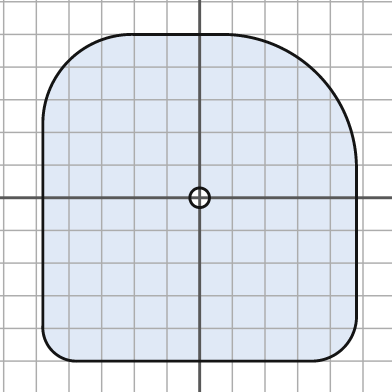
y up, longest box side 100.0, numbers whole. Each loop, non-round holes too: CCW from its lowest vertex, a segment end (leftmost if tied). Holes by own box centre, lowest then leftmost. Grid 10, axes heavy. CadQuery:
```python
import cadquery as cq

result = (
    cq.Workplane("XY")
    .moveTo(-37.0, -50.0)
    .lineTo(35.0, -50.0)
    .threePointArc((44.0, -46.0), (48.0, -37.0))
    .lineTo(48.0, 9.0)
    .threePointArc((36.0, 38.0), (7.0, 50.0))
    .lineTo(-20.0, 50.0)
    .threePointArc((-40.0, 42.0), (-48.0, 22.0))
    .lineTo(-48.0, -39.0)
    .threePointArc((-45.0, -47.0), (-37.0, -50.0))
    .close()
    .moveTo(0.0, 0.0)
    .circle(3.0)
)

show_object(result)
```